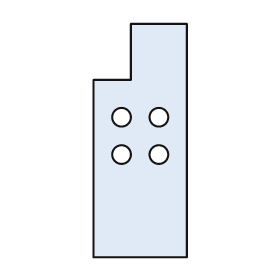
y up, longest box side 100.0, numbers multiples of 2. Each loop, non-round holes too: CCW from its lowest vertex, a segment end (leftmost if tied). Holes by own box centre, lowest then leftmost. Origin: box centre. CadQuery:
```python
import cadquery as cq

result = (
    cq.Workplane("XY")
    .moveTo(-20.0, -50.0)
    .lineTo(20.0, -50.0)
    .lineTo(20.0, 50.0)
    .lineTo(-4.0, 50.0)
    .lineTo(-4.0, 26.0)
    .lineTo(-20.0, 26.0)
    .close()
    .moveTo(-8.0, -6.0)
    .circle(4.0)
    .moveTo(8.0, -6.0)
    .circle(4.0)
    .moveTo(-8.0, 10.0)
    .circle(4.0)
    .moveTo(8.0, 10.0)
    .circle(4.0)
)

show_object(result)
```